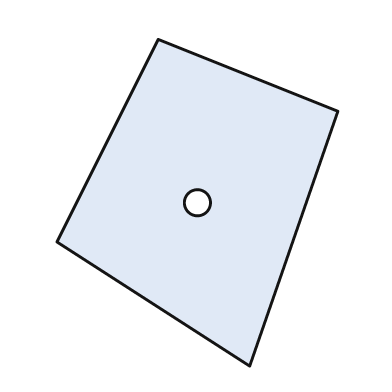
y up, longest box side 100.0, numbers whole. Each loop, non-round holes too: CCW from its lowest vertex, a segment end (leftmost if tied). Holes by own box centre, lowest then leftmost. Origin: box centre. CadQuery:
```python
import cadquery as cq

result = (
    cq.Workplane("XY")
    .moveTo(16.0, -50.0)
    .lineTo(43.0, 28.0)
    .lineTo(-12.0, 50.0)
    .lineTo(-43.0, -12.0)
    .close()
    .moveTo(0.0, 0.0)
    .circle(4.0)
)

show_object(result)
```